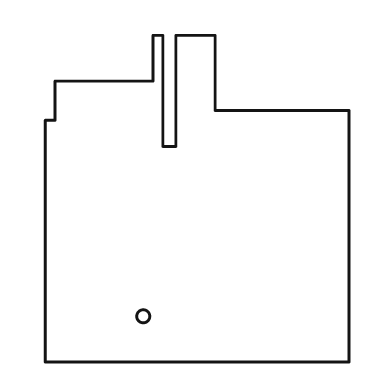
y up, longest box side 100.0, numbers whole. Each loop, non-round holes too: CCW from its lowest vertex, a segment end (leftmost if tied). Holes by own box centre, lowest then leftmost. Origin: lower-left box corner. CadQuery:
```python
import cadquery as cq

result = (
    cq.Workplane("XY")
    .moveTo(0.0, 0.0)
    .lineTo(93.0, 0.0)
    .lineTo(93.0, 77.0)
    .lineTo(52.0, 77.0)
    .lineTo(52.0, 100.0)
    .lineTo(40.0, 100.0)
    .lineTo(40.0, 66.0)
    .lineTo(36.0, 66.0)
    .lineTo(36.0, 100.0)
    .lineTo(33.0, 100.0)
    .lineTo(33.0, 86.0)
    .lineTo(3.0, 86.0)
    .lineTo(3.0, 74.0)
    .lineTo(0.0, 74.0)
    .close()
    .moveTo(30.0, 14.0)
    .circle(2.0)
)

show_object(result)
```